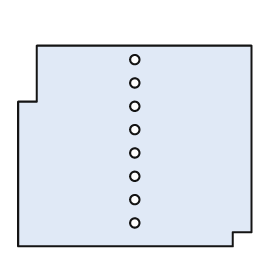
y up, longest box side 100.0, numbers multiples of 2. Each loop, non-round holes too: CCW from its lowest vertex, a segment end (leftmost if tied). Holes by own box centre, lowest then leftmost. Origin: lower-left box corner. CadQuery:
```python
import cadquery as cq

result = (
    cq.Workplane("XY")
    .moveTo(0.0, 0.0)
    .lineTo(92.0, 0.0)
    .lineTo(92.0, 6.0)
    .lineTo(100.0, 6.0)
    .lineTo(100.0, 86.0)
    .lineTo(8.0, 86.0)
    .lineTo(8.0, 62.0)
    .lineTo(0.0, 62.0)
    .close()
    .moveTo(50.0, 10.0)
    .circle(2.0)
    .moveTo(50.0, 20.0)
    .circle(2.0)
    .moveTo(50.0, 30.0)
    .circle(2.0)
    .moveTo(50.0, 40.0)
    .circle(2.0)
    .moveTo(50.0, 50.0)
    .circle(2.0)
    .moveTo(50.0, 60.0)
    .circle(2.0)
    .moveTo(50.0, 70.0)
    .circle(2.0)
    .moveTo(50.0, 80.0)
    .circle(2.0)
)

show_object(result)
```